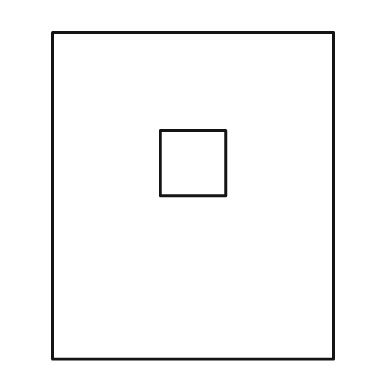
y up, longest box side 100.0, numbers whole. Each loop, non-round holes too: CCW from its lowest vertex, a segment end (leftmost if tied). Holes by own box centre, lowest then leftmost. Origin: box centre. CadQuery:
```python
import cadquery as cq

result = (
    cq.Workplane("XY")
    .moveTo(-43.0, -50.0)
    .lineTo(43.0, -50.0)
    .lineTo(43.0, 50.0)
    .lineTo(-43.0, 50.0)
    .close()
    .moveTo(-10.0, 0.0)
    .lineTo(10.0, 0.0)
    .lineTo(10.0, 20.0)
    .lineTo(-10.0, 20.0)
    .close()
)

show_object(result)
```